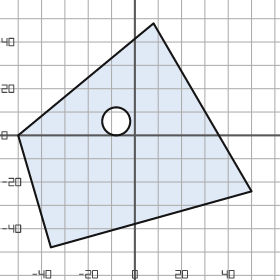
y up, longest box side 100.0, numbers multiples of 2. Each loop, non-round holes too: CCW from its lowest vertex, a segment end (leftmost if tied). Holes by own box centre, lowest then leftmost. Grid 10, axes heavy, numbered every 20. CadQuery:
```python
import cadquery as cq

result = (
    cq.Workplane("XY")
    .moveTo(-36.0, -48.0)
    .lineTo(50.0, -24.0)
    .lineTo(8.0, 48.0)
    .lineTo(-50.0, 0.0)
    .close()
    .moveTo(-8.0, 6.0)
    .circle(6.0)
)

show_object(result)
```